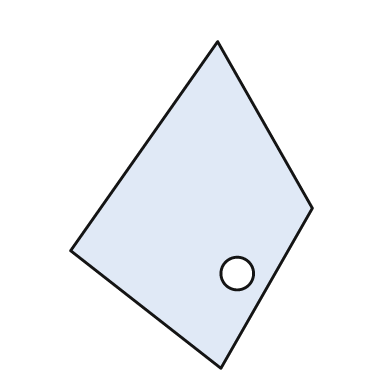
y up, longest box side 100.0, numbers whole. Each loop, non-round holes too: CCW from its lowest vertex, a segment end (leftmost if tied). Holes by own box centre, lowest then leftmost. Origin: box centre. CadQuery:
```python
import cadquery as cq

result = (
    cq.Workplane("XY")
    .moveTo(9.0, -50.0)
    .lineTo(37.0, -1.0)
    .lineTo(8.0, 50.0)
    .lineTo(-37.0, -14.0)
    .close()
    .moveTo(14.0, -21.0)
    .circle(5.0)
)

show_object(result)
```